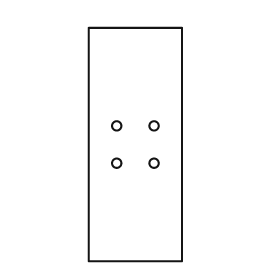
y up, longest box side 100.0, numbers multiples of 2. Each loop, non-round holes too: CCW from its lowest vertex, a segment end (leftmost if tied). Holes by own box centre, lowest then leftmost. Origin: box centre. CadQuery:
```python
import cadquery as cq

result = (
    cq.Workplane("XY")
    .moveTo(-20.0, -50.0)
    .lineTo(20.0, -50.0)
    .lineTo(20.0, 50.0)
    .lineTo(-20.0, 50.0)
    .close()
    .moveTo(-8.0, -8.0)
    .circle(2.0)
    .moveTo(8.0, -8.0)
    .circle(2.0)
    .moveTo(-8.0, 8.0)
    .circle(2.0)
    .moveTo(8.0, 8.0)
    .circle(2.0)
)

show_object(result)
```